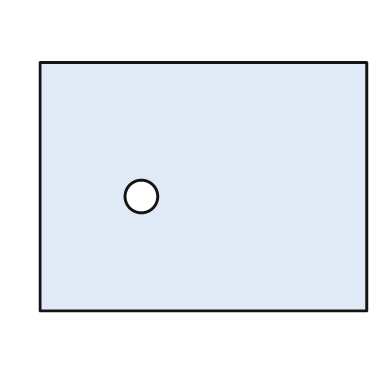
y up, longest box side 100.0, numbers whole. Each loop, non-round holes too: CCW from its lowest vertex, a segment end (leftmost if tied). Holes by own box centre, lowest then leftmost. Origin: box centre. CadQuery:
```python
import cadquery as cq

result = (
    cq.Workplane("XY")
    .moveTo(-50.0, -38.0)
    .lineTo(50.0, -38.0)
    .lineTo(50.0, 38.0)
    .lineTo(-50.0, 38.0)
    .close()
    .moveTo(-19.0, -3.0)
    .circle(5.0)
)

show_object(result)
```